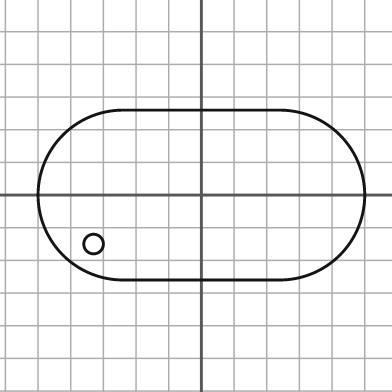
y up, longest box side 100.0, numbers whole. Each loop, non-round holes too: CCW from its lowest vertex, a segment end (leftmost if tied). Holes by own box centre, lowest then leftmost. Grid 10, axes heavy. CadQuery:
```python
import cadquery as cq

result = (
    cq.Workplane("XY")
    .moveTo(-24.0, -26.0)
    .lineTo(24.0, -26.0)
    .threePointArc((50.0, 0.0), (24.0, 26.0))
    .lineTo(-24.0, 26.0)
    .threePointArc((-50.0, 0.0), (-24.0, -26.0))
    .close()
    .moveTo(-33.0, -15.0)
    .circle(3.0)
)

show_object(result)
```